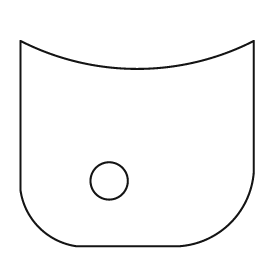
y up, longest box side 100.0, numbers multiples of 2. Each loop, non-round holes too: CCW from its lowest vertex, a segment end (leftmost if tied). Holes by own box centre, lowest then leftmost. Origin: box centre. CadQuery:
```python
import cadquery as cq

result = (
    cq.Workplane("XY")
    .moveTo(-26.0, -44.0)
    .lineTo(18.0, -44.0)
    .threePointArc((40.0, -34.0), (50.0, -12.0))
    .lineTo(50.0, 44.0)
    .threePointArc((0.0, 32.0), (-50.0, 44.0))
    .lineTo(-50.0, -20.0)
    .threePointArc((-42.0, -36.0), (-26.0, -44.0))
    .close()
    .moveTo(-12.0, -16.0)
    .circle(8.0)
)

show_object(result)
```